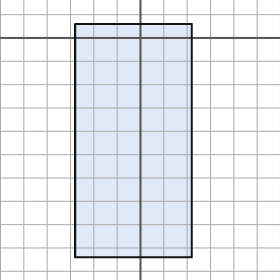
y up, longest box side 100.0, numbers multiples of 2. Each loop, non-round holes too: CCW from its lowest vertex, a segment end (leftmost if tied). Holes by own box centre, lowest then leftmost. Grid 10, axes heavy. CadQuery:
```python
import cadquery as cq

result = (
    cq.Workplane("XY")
    .moveTo(-28.0, -94.0)
    .lineTo(22.0, -94.0)
    .lineTo(22.0, 6.0)
    .lineTo(-28.0, 6.0)
    .close()
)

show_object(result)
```